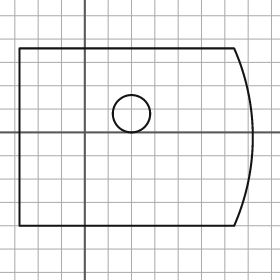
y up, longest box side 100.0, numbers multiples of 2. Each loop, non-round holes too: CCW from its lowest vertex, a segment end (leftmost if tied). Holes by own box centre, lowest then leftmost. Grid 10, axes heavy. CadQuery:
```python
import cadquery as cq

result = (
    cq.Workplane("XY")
    .moveTo(-28.0, -40.0)
    .lineTo(64.0, -40.0)
    .threePointArc((72.0, -2.0), (64.0, 36.0))
    .lineTo(-28.0, 36.0)
    .close()
    .moveTo(20.0, 8.0)
    .circle(8.0)
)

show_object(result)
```